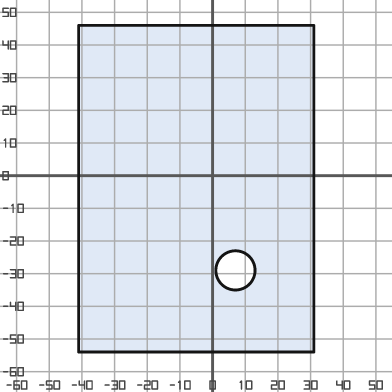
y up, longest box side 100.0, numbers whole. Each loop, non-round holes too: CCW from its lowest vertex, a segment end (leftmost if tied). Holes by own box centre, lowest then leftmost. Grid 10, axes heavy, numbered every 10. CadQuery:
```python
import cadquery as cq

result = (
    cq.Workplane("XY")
    .moveTo(-41.0, -54.0)
    .lineTo(31.0, -54.0)
    .lineTo(31.0, 46.0)
    .lineTo(-41.0, 46.0)
    .close()
    .moveTo(7.0, -29.0)
    .circle(6.0)
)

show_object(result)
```